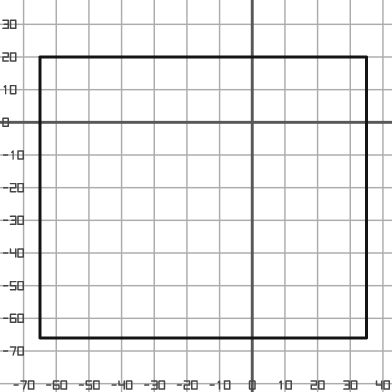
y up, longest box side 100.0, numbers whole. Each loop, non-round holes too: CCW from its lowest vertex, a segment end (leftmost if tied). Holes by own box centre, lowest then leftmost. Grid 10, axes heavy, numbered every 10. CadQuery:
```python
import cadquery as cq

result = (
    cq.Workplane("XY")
    .moveTo(-65.0, -66.0)
    .lineTo(35.0, -66.0)
    .lineTo(35.0, 20.0)
    .lineTo(-65.0, 20.0)
    .close()
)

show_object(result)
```